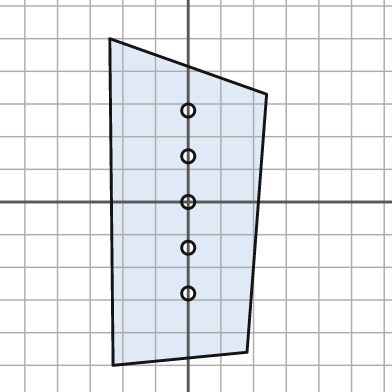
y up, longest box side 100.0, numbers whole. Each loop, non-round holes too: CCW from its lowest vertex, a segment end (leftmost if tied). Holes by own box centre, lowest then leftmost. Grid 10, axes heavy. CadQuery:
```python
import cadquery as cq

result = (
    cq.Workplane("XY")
    .moveTo(-23.0, -50.0)
    .lineTo(18.0, -46.0)
    .lineTo(24.0, 33.0)
    .lineTo(-24.0, 50.0)
    .close()
    .moveTo(0.0, -28.0)
    .circle(2.0)
    .moveTo(0.0, -14.0)
    .circle(2.0)
    .moveTo(0.0, 0.0)
    .circle(2.0)
    .moveTo(0.0, 14.0)
    .circle(2.0)
    .moveTo(0.0, 28.0)
    .circle(2.0)
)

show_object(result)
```